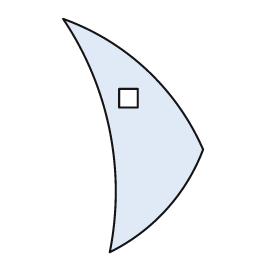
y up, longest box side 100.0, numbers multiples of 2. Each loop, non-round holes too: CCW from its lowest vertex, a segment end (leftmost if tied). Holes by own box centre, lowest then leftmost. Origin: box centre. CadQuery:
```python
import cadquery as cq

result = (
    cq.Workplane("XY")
    .moveTo(-10.0, -50.0)
    .threePointArc((14.0, -32.0), (30.0, -6.0))
    .threePointArc((6.0, 28.0), (-30.0, 50.0))
    .threePointArc((-10.0, 2.0), (-10.0, -50.0))
    .close()
    .moveTo(-6.0, 12.0)
    .lineTo(2.0, 12.0)
    .lineTo(2.0, 20.0)
    .lineTo(-6.0, 20.0)
    .close()
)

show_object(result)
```